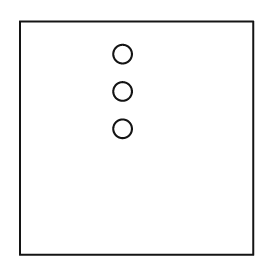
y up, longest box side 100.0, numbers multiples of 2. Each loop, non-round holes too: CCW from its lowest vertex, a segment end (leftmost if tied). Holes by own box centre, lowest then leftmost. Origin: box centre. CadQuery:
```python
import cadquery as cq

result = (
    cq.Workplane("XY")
    .moveTo(-50.0, -50.0)
    .lineTo(50.0, -50.0)
    .lineTo(50.0, 50.0)
    .lineTo(-50.0, 50.0)
    .close()
    .moveTo(-6.0, 4.0)
    .circle(4.0)
    .moveTo(-6.0, 20.0)
    .circle(4.0)
    .moveTo(-6.0, 36.0)
    .circle(4.0)
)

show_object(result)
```